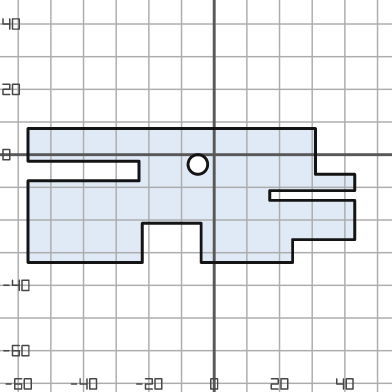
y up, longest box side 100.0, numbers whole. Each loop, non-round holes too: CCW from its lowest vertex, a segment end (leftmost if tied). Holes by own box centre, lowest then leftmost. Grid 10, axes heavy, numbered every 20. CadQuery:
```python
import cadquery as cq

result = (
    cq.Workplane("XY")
    .moveTo(-57.0, -33.0)
    .lineTo(-22.0, -33.0)
    .lineTo(-22.0, -21.0)
    .lineTo(-4.0, -21.0)
    .lineTo(-4.0, -33.0)
    .lineTo(24.0, -33.0)
    .lineTo(24.0, -26.0)
    .lineTo(43.0, -26.0)
    .lineTo(43.0, -14.0)
    .lineTo(17.0, -14.0)
    .lineTo(17.0, -11.0)
    .lineTo(43.0, -11.0)
    .lineTo(43.0, -6.0)
    .lineTo(31.0, -6.0)
    .lineTo(31.0, 8.0)
    .lineTo(-57.0, 8.0)
    .lineTo(-57.0, -2.0)
    .lineTo(-23.0, -2.0)
    .lineTo(-23.0, -8.0)
    .lineTo(-57.0, -8.0)
    .close()
    .moveTo(-5.0, -3.0)
    .circle(3.0)
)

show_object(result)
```